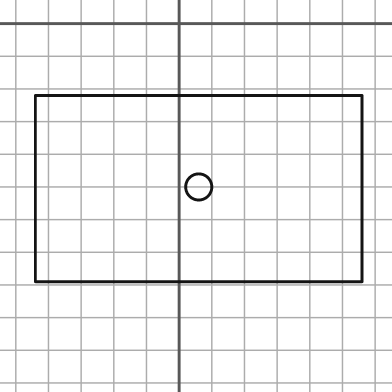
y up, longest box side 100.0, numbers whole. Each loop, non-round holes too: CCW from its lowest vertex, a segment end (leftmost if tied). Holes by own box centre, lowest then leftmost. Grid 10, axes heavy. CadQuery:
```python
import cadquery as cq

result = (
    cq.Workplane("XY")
    .moveTo(-44.0, -79.0)
    .lineTo(56.0, -79.0)
    .lineTo(56.0, -22.0)
    .lineTo(-44.0, -22.0)
    .close()
    .moveTo(6.0, -50.0)
    .circle(4.0)
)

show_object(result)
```